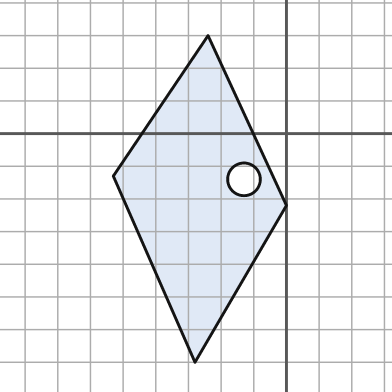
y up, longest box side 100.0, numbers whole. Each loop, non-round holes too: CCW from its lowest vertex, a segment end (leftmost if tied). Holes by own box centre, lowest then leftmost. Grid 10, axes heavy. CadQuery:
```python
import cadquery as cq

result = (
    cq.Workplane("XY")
    .moveTo(-28.0, -70.0)
    .lineTo(0.0, -22.0)
    .lineTo(-24.0, 30.0)
    .lineTo(-53.0, -13.0)
    .close()
    .moveTo(-13.0, -14.0)
    .circle(5.0)
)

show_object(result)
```